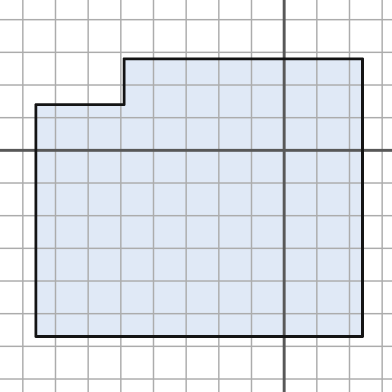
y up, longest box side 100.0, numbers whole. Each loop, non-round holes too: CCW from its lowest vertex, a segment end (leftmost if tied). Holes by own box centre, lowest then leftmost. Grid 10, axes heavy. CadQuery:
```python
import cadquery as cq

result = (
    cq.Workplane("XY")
    .moveTo(-76.0, -57.0)
    .lineTo(24.0, -57.0)
    .lineTo(24.0, 28.0)
    .lineTo(-49.0, 28.0)
    .lineTo(-49.0, 14.0)
    .lineTo(-76.0, 14.0)
    .close()
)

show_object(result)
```